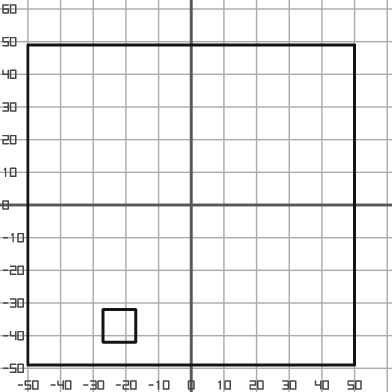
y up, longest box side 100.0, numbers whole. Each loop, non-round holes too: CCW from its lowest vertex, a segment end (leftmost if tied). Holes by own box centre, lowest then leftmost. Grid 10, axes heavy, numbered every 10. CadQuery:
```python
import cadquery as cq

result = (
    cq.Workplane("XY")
    .moveTo(-50.0, -49.0)
    .lineTo(50.0, -49.0)
    .lineTo(50.0, 49.0)
    .lineTo(-50.0, 49.0)
    .close()
    .moveTo(-27.0, -42.0)
    .lineTo(-17.0, -42.0)
    .lineTo(-17.0, -32.0)
    .lineTo(-27.0, -32.0)
    .close()
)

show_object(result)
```